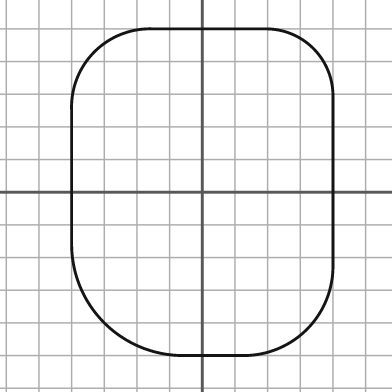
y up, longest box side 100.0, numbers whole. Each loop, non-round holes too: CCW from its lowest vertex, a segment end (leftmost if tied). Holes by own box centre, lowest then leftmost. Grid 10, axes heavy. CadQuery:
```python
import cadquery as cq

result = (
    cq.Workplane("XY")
    .moveTo(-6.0, -50.0)
    .lineTo(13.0, -50.0)
    .threePointArc((32.0, -42.0), (40.0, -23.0))
    .lineTo(40.0, 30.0)
    .threePointArc((34.0, 44.0), (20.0, 50.0))
    .lineTo(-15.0, 50.0)
    .threePointArc((-33.0, 43.0), (-40.0, 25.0))
    .lineTo(-40.0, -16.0)
    .threePointArc((-30.0, -40.0), (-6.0, -50.0))
    .close()
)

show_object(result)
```